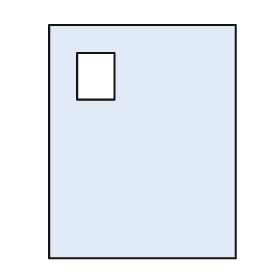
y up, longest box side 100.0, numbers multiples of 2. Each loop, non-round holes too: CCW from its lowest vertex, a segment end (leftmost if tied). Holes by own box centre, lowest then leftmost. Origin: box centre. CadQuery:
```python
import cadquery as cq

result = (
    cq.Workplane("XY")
    .moveTo(-40.0, -50.0)
    .lineTo(40.0, -50.0)
    .lineTo(40.0, 50.0)
    .lineTo(-40.0, 50.0)
    .close()
    .moveTo(-28.0, 18.0)
    .lineTo(-12.0, 18.0)
    .lineTo(-12.0, 38.0)
    .lineTo(-28.0, 38.0)
    .close()
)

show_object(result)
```